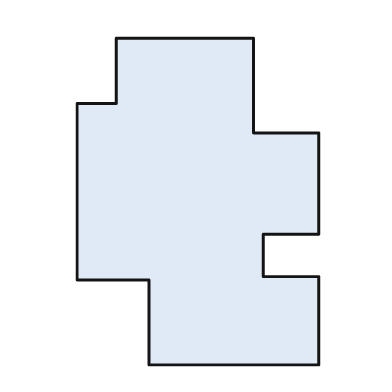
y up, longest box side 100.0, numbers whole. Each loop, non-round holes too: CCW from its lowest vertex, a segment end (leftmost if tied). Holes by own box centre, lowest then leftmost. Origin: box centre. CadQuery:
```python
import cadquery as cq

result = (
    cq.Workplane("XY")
    .moveTo(-15.0, -50.0)
    .lineTo(37.0, -50.0)
    .lineTo(37.0, -23.0)
    .lineTo(20.0, -23.0)
    .lineTo(20.0, -10.0)
    .lineTo(37.0, -10.0)
    .lineTo(37.0, 21.0)
    .lineTo(17.0, 21.0)
    .lineTo(17.0, 50.0)
    .lineTo(-25.0, 50.0)
    .lineTo(-25.0, 30.0)
    .lineTo(-37.0, 30.0)
    .lineTo(-37.0, -24.0)
    .lineTo(-15.0, -24.0)
    .close()
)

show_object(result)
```